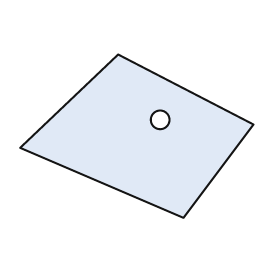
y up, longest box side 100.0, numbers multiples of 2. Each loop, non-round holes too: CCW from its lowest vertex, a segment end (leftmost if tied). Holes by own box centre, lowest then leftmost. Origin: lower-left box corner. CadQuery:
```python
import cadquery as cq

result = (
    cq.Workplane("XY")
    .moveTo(70.0, 0.0)
    .lineTo(100.0, 40.0)
    .lineTo(42.0, 70.0)
    .lineTo(0.0, 30.0)
    .close()
    .moveTo(60.0, 42.0)
    .circle(4.0)
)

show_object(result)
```